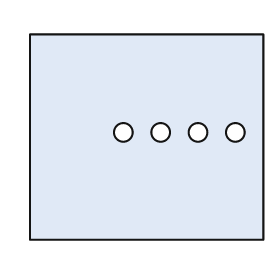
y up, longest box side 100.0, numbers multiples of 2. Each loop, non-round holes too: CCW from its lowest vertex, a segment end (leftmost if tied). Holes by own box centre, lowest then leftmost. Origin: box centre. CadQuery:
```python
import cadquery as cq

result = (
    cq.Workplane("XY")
    .moveTo(-50.0, -44.0)
    .lineTo(50.0, -44.0)
    .lineTo(50.0, 44.0)
    .lineTo(-50.0, 44.0)
    .close()
    .moveTo(-10.0, 2.0)
    .circle(4.0)
    .moveTo(6.0, 2.0)
    .circle(4.0)
    .moveTo(22.0, 2.0)
    .circle(4.0)
    .moveTo(38.0, 2.0)
    .circle(4.0)
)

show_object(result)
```